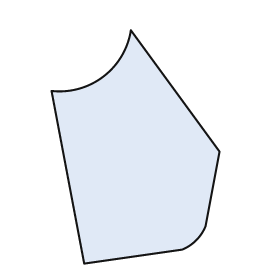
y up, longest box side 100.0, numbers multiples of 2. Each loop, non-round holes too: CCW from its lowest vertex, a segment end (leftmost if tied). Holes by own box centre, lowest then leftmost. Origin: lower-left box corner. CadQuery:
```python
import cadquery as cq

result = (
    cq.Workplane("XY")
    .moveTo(14.0, 0.0)
    .lineTo(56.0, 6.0)
    .threePointArc((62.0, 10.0), (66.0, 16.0))
    .lineTo(72.0, 48.0)
    .lineTo(34.0, 100.0)
    .threePointArc((22.0, 80.0), (0.0, 74.0))
    .close()
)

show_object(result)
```